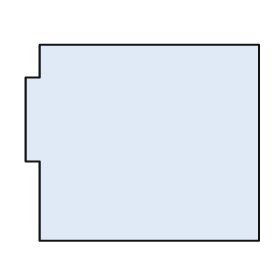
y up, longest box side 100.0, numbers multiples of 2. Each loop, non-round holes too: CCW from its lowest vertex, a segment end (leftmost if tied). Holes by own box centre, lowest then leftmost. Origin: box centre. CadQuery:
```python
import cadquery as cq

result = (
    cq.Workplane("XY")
    .moveTo(-44.0, -42.0)
    .lineTo(50.0, -42.0)
    .lineTo(50.0, 42.0)
    .lineTo(-44.0, 42.0)
    .lineTo(-44.0, 28.0)
    .lineTo(-50.0, 28.0)
    .lineTo(-50.0, -8.0)
    .lineTo(-44.0, -8.0)
    .close()
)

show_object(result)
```